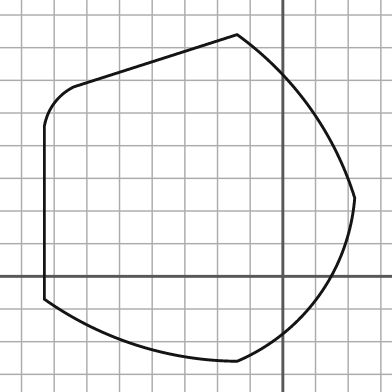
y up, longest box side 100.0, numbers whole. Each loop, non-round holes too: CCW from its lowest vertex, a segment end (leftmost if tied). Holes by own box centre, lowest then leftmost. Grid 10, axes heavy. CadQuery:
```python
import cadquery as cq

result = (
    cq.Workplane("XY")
    .moveTo(-14.0, -26.0)
    .threePointArc((11.0, -6.0), (22.0, 24.0))
    .threePointArc((8.0, 52.0), (-14.0, 74.0))
    .lineTo(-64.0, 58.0)
    .threePointArc((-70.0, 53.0), (-73.0, 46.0))
    .lineTo(-73.0, -7.0)
    .threePointArc((-45.0, -21.0), (-14.0, -26.0))
    .close()
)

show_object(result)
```